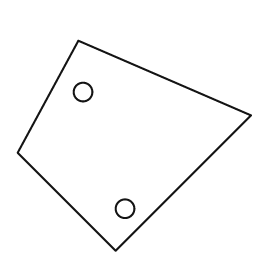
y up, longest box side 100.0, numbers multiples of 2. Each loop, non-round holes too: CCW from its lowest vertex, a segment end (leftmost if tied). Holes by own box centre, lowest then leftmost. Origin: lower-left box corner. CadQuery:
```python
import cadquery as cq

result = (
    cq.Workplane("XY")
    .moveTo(42.0, 0.0)
    .lineTo(100.0, 58.0)
    .lineTo(26.0, 90.0)
    .lineTo(0.0, 42.0)
    .close()
    .moveTo(46.0, 18.0)
    .circle(4.0)
    .moveTo(28.0, 68.0)
    .circle(4.0)
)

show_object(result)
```